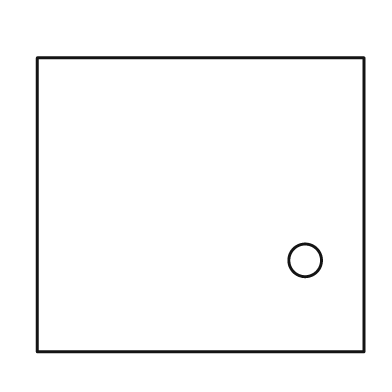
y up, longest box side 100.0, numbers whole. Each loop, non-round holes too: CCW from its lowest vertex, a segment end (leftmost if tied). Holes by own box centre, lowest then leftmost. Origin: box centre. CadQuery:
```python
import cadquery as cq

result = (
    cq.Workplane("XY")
    .moveTo(-50.0, -45.0)
    .lineTo(50.0, -45.0)
    .lineTo(50.0, 45.0)
    .lineTo(-50.0, 45.0)
    .close()
    .moveTo(32.0, -17.0)
    .circle(5.0)
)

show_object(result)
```